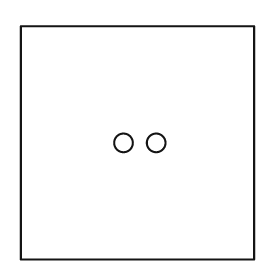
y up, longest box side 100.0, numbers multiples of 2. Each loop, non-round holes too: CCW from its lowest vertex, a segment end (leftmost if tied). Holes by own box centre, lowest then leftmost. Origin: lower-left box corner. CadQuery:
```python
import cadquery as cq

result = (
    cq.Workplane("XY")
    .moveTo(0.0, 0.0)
    .lineTo(100.0, 0.0)
    .lineTo(100.0, 100.0)
    .lineTo(0.0, 100.0)
    .close()
    .moveTo(44.0, 50.0)
    .circle(4.0)
    .moveTo(58.0, 50.0)
    .circle(4.0)
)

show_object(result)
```